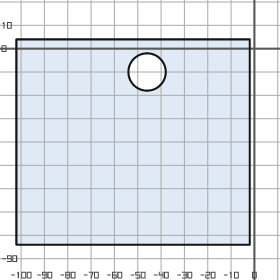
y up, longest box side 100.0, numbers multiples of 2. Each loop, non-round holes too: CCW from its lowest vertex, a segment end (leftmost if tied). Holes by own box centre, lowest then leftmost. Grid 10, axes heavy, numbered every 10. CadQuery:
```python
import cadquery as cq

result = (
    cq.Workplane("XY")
    .moveTo(-102.0, -84.0)
    .lineTo(-2.0, -84.0)
    .lineTo(-2.0, 4.0)
    .lineTo(-102.0, 4.0)
    .close()
    .moveTo(-46.0, -10.0)
    .circle(8.0)
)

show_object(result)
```